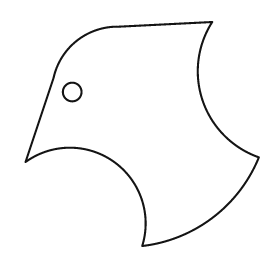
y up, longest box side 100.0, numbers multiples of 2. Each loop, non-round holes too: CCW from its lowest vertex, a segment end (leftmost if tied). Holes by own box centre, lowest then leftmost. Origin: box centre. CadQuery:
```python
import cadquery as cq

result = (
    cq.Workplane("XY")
    .moveTo(0.0, -48.0)
    .threePointArc((30.0, -36.0), (50.0, -10.0))
    .threePointArc((26.0, 14.0), (30.0, 48.0))
    .lineTo(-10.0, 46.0)
    .threePointArc((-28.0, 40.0), (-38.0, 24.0))
    .lineTo(-50.0, -12.0)
    .threePointArc((-12.0, -12.0), (0.0, -48.0))
    .close()
    .moveTo(-30.0, 18.0)
    .circle(4.0)
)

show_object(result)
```